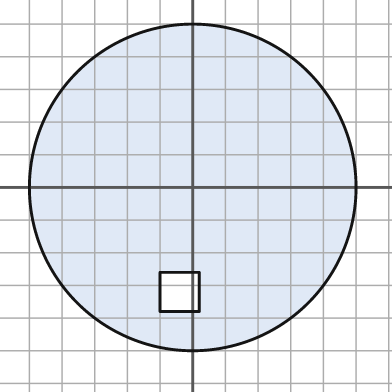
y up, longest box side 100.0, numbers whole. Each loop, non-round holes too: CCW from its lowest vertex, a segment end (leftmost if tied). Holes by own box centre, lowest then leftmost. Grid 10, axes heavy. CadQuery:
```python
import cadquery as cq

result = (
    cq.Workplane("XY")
    .moveTo(0.0, 0.0)
    .circle(50.0)
    .moveTo(-10.0, -38.0)
    .lineTo(2.0, -38.0)
    .lineTo(2.0, -26.0)
    .lineTo(-10.0, -26.0)
    .close()
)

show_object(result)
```